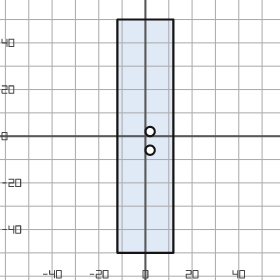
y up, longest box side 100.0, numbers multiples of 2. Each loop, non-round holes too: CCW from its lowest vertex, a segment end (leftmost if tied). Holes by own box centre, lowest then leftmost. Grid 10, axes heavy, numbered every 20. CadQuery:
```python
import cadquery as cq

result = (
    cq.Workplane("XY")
    .moveTo(-12.0, -50.0)
    .lineTo(12.0, -50.0)
    .lineTo(12.0, 50.0)
    .lineTo(-12.0, 50.0)
    .close()
    .moveTo(2.0, -6.0)
    .circle(2.0)
    .moveTo(2.0, 2.0)
    .circle(2.0)
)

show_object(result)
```